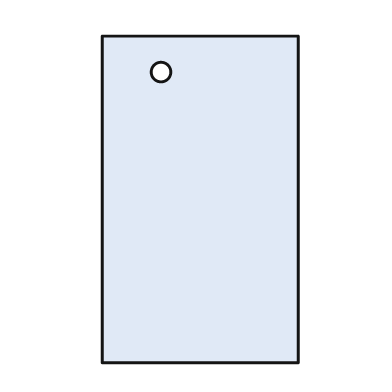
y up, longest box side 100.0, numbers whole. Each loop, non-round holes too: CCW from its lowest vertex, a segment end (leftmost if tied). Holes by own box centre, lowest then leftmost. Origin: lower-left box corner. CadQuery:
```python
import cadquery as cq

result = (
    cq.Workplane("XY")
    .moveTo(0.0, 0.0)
    .lineTo(60.0, 0.0)
    .lineTo(60.0, 100.0)
    .lineTo(0.0, 100.0)
    .close()
    .moveTo(18.0, 89.0)
    .circle(3.0)
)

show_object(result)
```